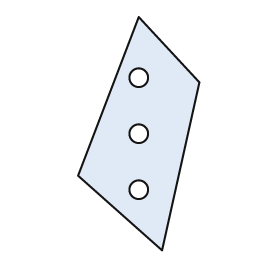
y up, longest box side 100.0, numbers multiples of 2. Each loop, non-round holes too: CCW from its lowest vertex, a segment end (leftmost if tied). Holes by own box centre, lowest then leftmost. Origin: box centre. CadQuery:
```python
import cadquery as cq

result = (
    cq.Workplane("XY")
    .moveTo(10.0, -50.0)
    .lineTo(26.0, 22.0)
    .lineTo(0.0, 50.0)
    .lineTo(-26.0, -18.0)
    .close()
    .moveTo(0.0, -24.0)
    .circle(4.0)
    .moveTo(0.0, 0.0)
    .circle(4.0)
    .moveTo(0.0, 24.0)
    .circle(4.0)
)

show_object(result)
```